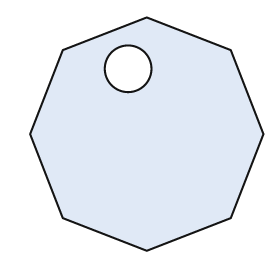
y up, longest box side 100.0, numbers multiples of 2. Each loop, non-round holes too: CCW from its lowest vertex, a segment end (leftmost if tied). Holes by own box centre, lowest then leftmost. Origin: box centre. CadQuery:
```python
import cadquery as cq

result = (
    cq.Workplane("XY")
    .moveTo(0.0, -50.0)
    .lineTo(36.0, -36.0)
    .lineTo(50.0, 0.0)
    .lineTo(36.0, 36.0)
    .lineTo(0.0, 50.0)
    .lineTo(-36.0, 36.0)
    .lineTo(-50.0, 0.0)
    .lineTo(-36.0, -36.0)
    .close()
    .moveTo(-8.0, 28.0)
    .circle(10.0)
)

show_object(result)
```